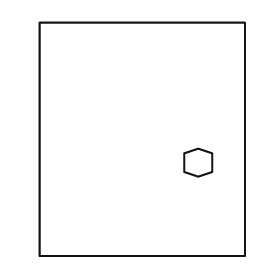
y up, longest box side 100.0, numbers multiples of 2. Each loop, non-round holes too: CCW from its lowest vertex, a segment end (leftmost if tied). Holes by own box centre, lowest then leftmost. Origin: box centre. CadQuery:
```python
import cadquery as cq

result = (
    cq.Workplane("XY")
    .moveTo(-44.0, -50.0)
    .lineTo(44.0, -50.0)
    .lineTo(44.0, 50.0)
    .lineTo(-44.0, 50.0)
    .close()
    .moveTo(24.0, -16.0)
    .lineTo(30.0, -14.0)
    .lineTo(30.0, -6.0)
    .lineTo(24.0, -4.0)
    .lineTo(18.0, -6.0)
    .lineTo(18.0, -14.0)
    .close()
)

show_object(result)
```